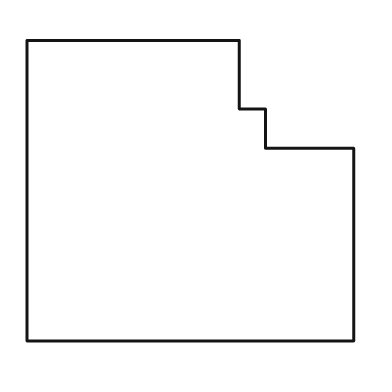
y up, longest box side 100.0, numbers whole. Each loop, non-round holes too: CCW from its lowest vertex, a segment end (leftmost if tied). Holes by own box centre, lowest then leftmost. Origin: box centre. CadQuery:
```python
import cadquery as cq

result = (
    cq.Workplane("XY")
    .moveTo(-50.0, -46.0)
    .lineTo(50.0, -46.0)
    .lineTo(50.0, 13.0)
    .lineTo(23.0, 13.0)
    .lineTo(23.0, 25.0)
    .lineTo(15.0, 25.0)
    .lineTo(15.0, 46.0)
    .lineTo(-50.0, 46.0)
    .close()
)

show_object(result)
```